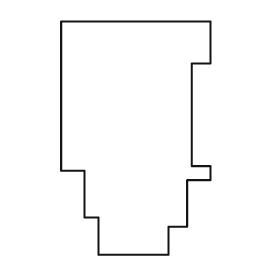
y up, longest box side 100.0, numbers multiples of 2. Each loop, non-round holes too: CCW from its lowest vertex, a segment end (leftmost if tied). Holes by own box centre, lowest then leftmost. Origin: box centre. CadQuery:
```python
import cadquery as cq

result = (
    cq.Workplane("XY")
    .moveTo(-16.0, -50.0)
    .lineTo(14.0, -50.0)
    .lineTo(14.0, -38.0)
    .lineTo(22.0, -38.0)
    .lineTo(22.0, -18.0)
    .lineTo(32.0, -18.0)
    .lineTo(32.0, -12.0)
    .lineTo(24.0, -12.0)
    .lineTo(24.0, 32.0)
    .lineTo(32.0, 32.0)
    .lineTo(32.0, 50.0)
    .lineTo(-32.0, 50.0)
    .lineTo(-32.0, -14.0)
    .lineTo(-22.0, -14.0)
    .lineTo(-22.0, -34.0)
    .lineTo(-16.0, -34.0)
    .close()
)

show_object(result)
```